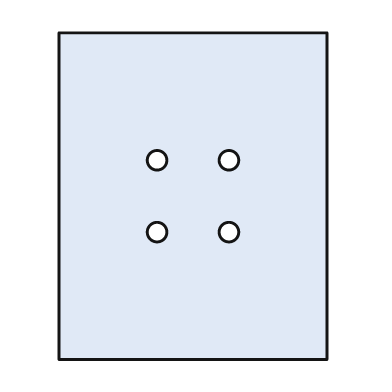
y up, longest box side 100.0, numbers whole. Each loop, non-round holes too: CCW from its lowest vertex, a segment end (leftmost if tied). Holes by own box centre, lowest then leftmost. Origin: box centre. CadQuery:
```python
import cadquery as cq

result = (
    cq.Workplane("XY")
    .moveTo(-41.0, -50.0)
    .lineTo(41.0, -50.0)
    .lineTo(41.0, 50.0)
    .lineTo(-41.0, 50.0)
    .close()
    .moveTo(-11.0, -11.0)
    .circle(3.0)
    .moveTo(11.0, -11.0)
    .circle(3.0)
    .moveTo(-11.0, 11.0)
    .circle(3.0)
    .moveTo(11.0, 11.0)
    .circle(3.0)
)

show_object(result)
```